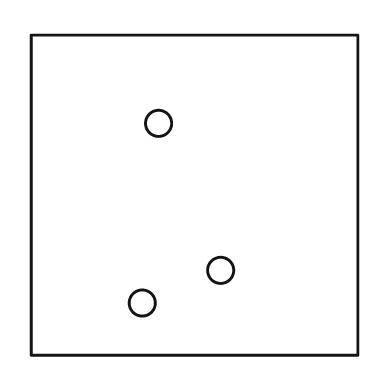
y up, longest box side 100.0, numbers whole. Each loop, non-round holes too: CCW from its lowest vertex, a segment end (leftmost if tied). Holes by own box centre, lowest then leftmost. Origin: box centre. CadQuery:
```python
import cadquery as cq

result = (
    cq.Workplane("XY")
    .moveTo(-50.0, -49.0)
    .lineTo(50.0, -49.0)
    .lineTo(50.0, 49.0)
    .lineTo(-50.0, 49.0)
    .close()
    .moveTo(-16.0, -33.0)
    .circle(4.0)
    .moveTo(8.0, -23.0)
    .circle(4.0)
    .moveTo(-11.0, 22.0)
    .circle(4.0)
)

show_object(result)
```